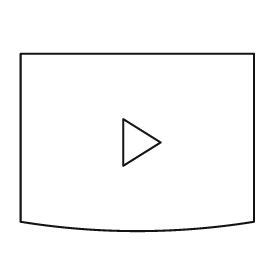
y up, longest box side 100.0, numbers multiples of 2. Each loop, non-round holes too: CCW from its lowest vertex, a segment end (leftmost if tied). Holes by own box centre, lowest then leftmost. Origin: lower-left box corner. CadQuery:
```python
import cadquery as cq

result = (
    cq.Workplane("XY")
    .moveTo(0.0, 4.0)
    .threePointArc((50.0, 0.0), (100.0, 4.0))
    .lineTo(100.0, 76.0)
    .lineTo(0.0, 76.0)
    .close()
    .moveTo(44.0, 28.0)
    .lineTo(60.0, 38.0)
    .lineTo(44.0, 48.0)
    .close()
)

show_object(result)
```